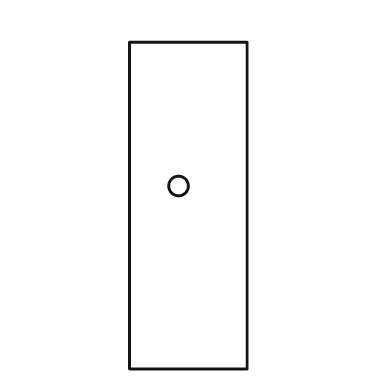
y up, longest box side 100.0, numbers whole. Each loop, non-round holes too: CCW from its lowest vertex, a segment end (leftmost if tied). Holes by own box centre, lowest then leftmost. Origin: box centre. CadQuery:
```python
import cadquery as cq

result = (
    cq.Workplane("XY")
    .moveTo(-18.0, -50.0)
    .lineTo(18.0, -50.0)
    .lineTo(18.0, 50.0)
    .lineTo(-18.0, 50.0)
    .close()
    .moveTo(-3.0, 6.0)
    .circle(3.0)
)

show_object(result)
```